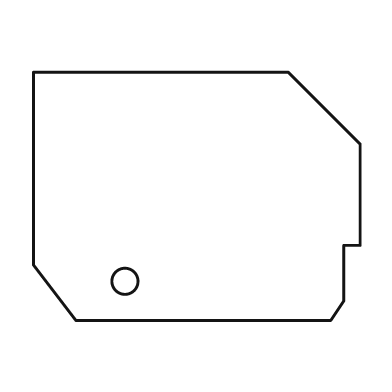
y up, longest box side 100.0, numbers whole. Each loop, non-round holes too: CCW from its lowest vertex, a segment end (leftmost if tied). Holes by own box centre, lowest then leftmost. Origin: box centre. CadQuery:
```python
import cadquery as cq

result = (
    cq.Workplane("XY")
    .moveTo(-37.0, -38.0)
    .lineTo(41.0, -38.0)
    .lineTo(45.0, -32.0)
    .lineTo(45.0, -15.0)
    .lineTo(50.0, -15.0)
    .lineTo(50.0, 16.0)
    .lineTo(28.0, 38.0)
    .lineTo(-50.0, 38.0)
    .lineTo(-50.0, -21.0)
    .close()
    .moveTo(-22.0, -26.0)
    .circle(4.0)
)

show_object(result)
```